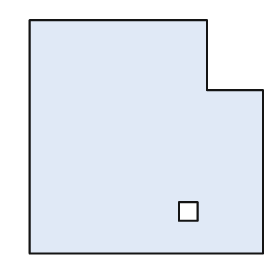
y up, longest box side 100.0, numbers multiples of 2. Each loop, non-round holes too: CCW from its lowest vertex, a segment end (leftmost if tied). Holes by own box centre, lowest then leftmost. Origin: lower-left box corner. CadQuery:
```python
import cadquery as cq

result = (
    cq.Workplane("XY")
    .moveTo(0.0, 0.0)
    .lineTo(100.0, 0.0)
    .lineTo(100.0, 70.0)
    .lineTo(76.0, 70.0)
    .lineTo(76.0, 100.0)
    .lineTo(0.0, 100.0)
    .close()
    .moveTo(64.0, 14.0)
    .lineTo(72.0, 14.0)
    .lineTo(72.0, 22.0)
    .lineTo(64.0, 22.0)
    .close()
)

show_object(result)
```